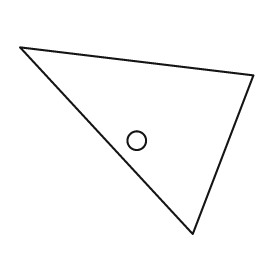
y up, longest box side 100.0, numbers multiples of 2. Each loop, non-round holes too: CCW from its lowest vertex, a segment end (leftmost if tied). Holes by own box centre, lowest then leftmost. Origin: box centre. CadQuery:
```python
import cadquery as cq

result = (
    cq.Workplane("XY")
    .moveTo(24.0, -40.0)
    .lineTo(50.0, 28.0)
    .lineTo(-50.0, 40.0)
    .close()
    .moveTo(0.0, 0.0)
    .circle(4.0)
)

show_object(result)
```